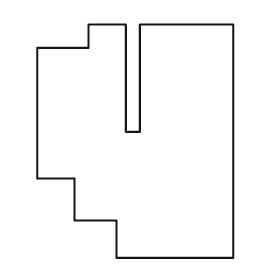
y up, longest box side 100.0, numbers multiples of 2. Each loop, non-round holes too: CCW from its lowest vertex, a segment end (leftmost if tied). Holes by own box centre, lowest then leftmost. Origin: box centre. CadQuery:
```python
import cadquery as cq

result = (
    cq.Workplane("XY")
    .moveTo(-8.0, -50.0)
    .lineTo(42.0, -50.0)
    .lineTo(42.0, 50.0)
    .lineTo(2.0, 50.0)
    .lineTo(2.0, 4.0)
    .lineTo(-4.0, 4.0)
    .lineTo(-4.0, 50.0)
    .lineTo(-20.0, 50.0)
    .lineTo(-20.0, 40.0)
    .lineTo(-42.0, 40.0)
    .lineTo(-42.0, -16.0)
    .lineTo(-26.0, -16.0)
    .lineTo(-26.0, -34.0)
    .lineTo(-8.0, -34.0)
    .close()
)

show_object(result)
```